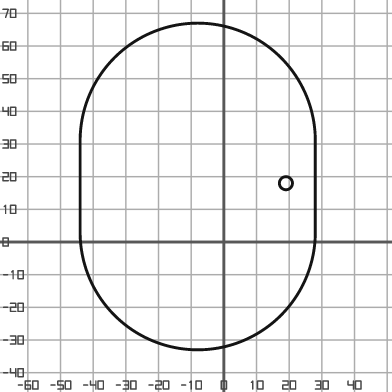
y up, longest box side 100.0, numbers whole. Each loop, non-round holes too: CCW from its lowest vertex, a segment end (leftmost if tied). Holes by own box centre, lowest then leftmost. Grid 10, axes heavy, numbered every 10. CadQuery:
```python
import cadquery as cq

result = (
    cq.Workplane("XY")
    .moveTo(-44.0, 3.0)
    .threePointArc((-8.0, -33.0), (28.0, 3.0))
    .lineTo(28.0, 31.0)
    .threePointArc((-8.0, 67.0), (-44.0, 31.0))
    .close()
    .moveTo(19.0, 18.0)
    .circle(2.0)
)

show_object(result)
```